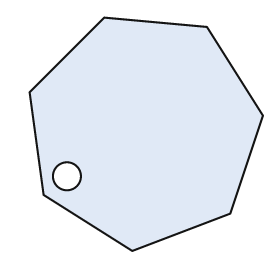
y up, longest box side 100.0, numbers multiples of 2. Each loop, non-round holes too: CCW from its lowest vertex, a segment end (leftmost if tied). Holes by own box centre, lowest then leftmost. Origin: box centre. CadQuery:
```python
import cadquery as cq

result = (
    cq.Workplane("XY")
    .moveTo(-6.0, -50.0)
    .lineTo(36.0, -34.0)
    .lineTo(50.0, 8.0)
    .lineTo(26.0, 46.0)
    .lineTo(-18.0, 50.0)
    .lineTo(-50.0, 18.0)
    .lineTo(-44.0, -26.0)
    .close()
    .moveTo(-34.0, -18.0)
    .circle(6.0)
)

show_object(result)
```